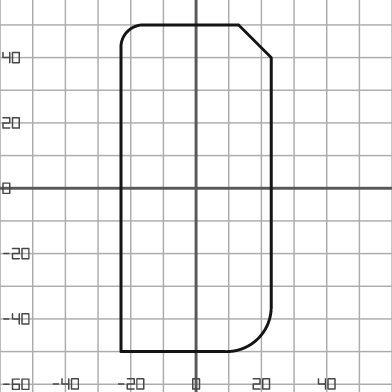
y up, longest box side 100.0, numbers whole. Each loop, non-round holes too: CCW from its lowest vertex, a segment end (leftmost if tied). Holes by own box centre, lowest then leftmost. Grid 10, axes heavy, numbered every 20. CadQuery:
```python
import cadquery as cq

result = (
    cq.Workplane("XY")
    .moveTo(-23.0, -50.0)
    .lineTo(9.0, -50.0)
    .threePointArc((19.0, -46.0), (23.0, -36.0))
    .lineTo(23.0, 40.0)
    .lineTo(13.0, 50.0)
    .lineTo(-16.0, 50.0)
    .threePointArc((-21.0, 48.0), (-23.0, 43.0))
    .close()
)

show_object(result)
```